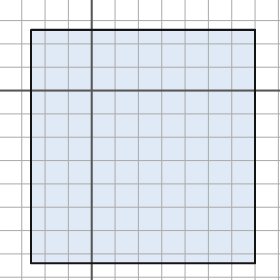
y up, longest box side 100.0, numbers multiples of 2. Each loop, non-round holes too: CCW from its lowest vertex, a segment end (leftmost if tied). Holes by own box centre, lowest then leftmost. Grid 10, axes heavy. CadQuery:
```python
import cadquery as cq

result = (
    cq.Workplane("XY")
    .moveTo(-26.0, -74.0)
    .lineTo(70.0, -74.0)
    .lineTo(70.0, 26.0)
    .lineTo(-26.0, 26.0)
    .close()
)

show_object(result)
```